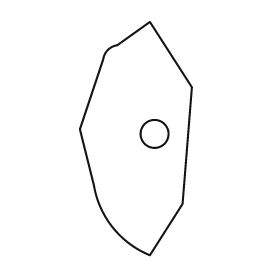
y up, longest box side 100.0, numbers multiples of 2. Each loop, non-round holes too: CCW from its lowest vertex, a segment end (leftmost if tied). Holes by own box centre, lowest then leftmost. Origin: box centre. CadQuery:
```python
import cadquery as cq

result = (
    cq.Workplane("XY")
    .moveTo(6.0, -50.0)
    .lineTo(20.0, -28.0)
    .lineTo(24.0, 22.0)
    .lineTo(6.0, 50.0)
    .lineTo(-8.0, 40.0)
    .threePointArc((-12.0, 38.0), (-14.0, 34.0))
    .lineTo(-24.0, 4.0)
    .lineTo(-18.0, -20.0)
    .threePointArc((-10.0, -38.0), (6.0, -50.0))
    .close()
    .moveTo(8.0, 2.0)
    .circle(6.0)
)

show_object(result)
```